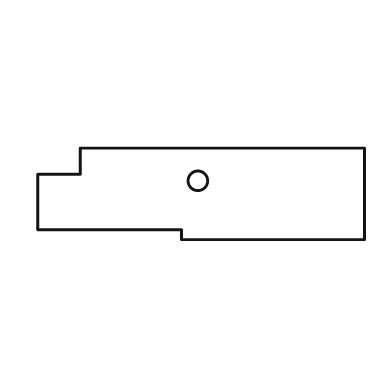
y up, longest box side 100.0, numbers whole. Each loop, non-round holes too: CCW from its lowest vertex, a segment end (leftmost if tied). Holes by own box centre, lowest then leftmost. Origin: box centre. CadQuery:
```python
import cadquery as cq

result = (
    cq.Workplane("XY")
    .moveTo(-6.0, -14.0)
    .lineTo(50.0, -14.0)
    .lineTo(50.0, 14.0)
    .lineTo(-37.0, 14.0)
    .lineTo(-37.0, 6.0)
    .lineTo(-50.0, 6.0)
    .lineTo(-50.0, -11.0)
    .lineTo(-6.0, -11.0)
    .close()
    .moveTo(-1.0, 4.0)
    .circle(3.0)
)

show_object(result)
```